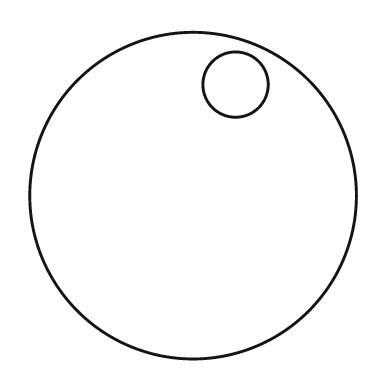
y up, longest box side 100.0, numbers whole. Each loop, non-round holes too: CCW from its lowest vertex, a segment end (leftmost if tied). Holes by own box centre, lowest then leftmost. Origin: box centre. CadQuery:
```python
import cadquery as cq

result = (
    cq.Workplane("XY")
    .moveTo(0.0, 0.0)
    .circle(50.0)
    .moveTo(13.0, 34.0)
    .circle(10.0)
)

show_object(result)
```